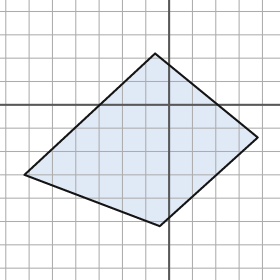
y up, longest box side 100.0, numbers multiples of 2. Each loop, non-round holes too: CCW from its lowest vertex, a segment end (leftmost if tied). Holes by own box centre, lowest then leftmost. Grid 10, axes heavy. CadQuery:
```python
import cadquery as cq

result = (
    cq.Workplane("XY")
    .moveTo(-4.0, -52.0)
    .lineTo(38.0, -14.0)
    .lineTo(-6.0, 22.0)
    .lineTo(-62.0, -30.0)
    .close()
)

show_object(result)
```